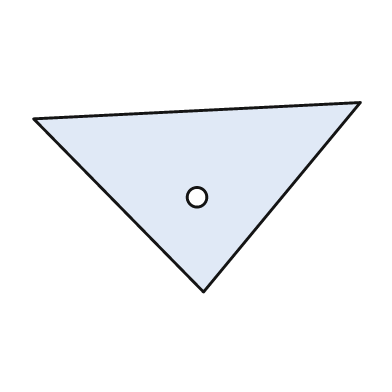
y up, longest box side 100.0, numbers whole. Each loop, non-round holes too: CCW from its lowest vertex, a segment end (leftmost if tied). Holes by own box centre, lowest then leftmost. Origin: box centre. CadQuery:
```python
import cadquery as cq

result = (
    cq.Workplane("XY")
    .moveTo(2.0, -29.0)
    .lineTo(50.0, 29.0)
    .lineTo(-50.0, 24.0)
    .close()
    .moveTo(0.0, 0.0)
    .circle(3.0)
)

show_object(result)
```